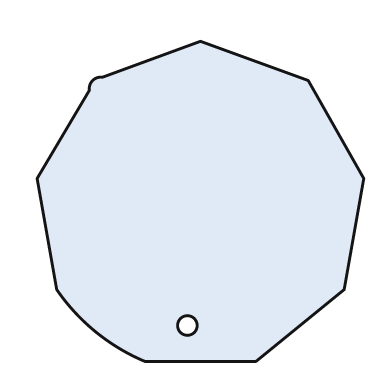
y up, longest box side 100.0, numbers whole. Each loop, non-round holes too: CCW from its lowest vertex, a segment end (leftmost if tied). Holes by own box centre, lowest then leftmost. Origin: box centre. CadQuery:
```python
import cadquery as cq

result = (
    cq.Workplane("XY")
    .moveTo(-17.0, -49.0)
    .lineTo(17.0, -49.0)
    .lineTo(44.0, -27.0)
    .lineTo(50.0, 7.0)
    .lineTo(33.0, 37.0)
    .lineTo(0.0, 49.0)
    .lineTo(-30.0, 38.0)
    .threePointArc((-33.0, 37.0), (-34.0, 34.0))
    .lineTo(-50.0, 7.0)
    .lineTo(-44.0, -27.0)
    .threePointArc((-32.0, -40.0), (-17.0, -49.0))
    .close()
    .moveTo(-4.0, -38.0)
    .circle(3.0)
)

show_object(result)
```